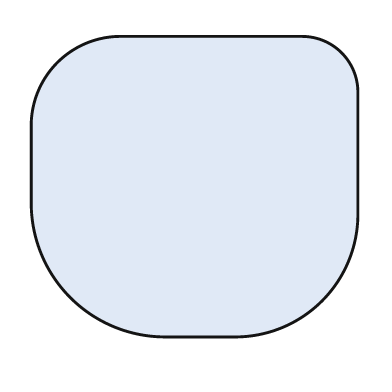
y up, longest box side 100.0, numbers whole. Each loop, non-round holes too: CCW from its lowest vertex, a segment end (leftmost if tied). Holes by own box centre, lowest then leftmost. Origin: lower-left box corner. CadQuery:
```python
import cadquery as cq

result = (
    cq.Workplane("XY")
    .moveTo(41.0, 0.0)
    .lineTo(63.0, 0.0)
    .threePointArc((89.0, 11.0), (100.0, 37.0))
    .lineTo(100.0, 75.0)
    .threePointArc((95.0, 87.0), (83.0, 92.0))
    .lineTo(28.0, 92.0)
    .threePointArc((8.0, 84.0), (0.0, 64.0))
    .lineTo(0.0, 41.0)
    .threePointArc((12.0, 12.0), (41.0, 0.0))
    .close()
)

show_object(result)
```